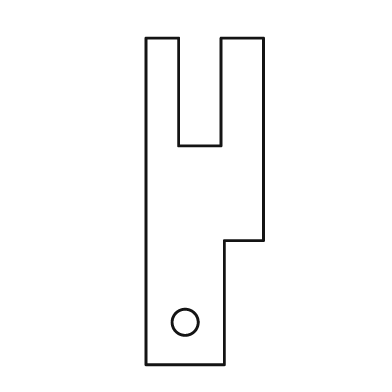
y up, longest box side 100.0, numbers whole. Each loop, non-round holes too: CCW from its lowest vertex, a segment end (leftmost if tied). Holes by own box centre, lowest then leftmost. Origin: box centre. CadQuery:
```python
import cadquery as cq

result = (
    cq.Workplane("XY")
    .moveTo(-18.0, -50.0)
    .lineTo(6.0, -50.0)
    .lineTo(6.0, -12.0)
    .lineTo(18.0, -12.0)
    .lineTo(18.0, 50.0)
    .lineTo(5.0, 50.0)
    .lineTo(5.0, 17.0)
    .lineTo(-8.0, 17.0)
    .lineTo(-8.0, 50.0)
    .lineTo(-18.0, 50.0)
    .close()
    .moveTo(-6.0, -37.0)
    .circle(4.0)
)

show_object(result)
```